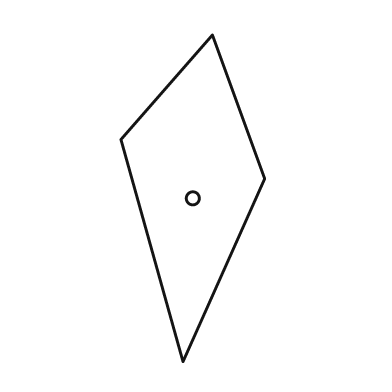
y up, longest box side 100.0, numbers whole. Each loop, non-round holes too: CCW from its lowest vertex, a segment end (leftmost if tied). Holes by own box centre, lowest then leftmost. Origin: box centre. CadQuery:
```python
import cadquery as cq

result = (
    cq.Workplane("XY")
    .moveTo(-3.0, -50.0)
    .lineTo(22.0, 6.0)
    .lineTo(6.0, 50.0)
    .lineTo(-22.0, 18.0)
    .close()
    .moveTo(0.0, 0.0)
    .circle(2.0)
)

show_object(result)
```